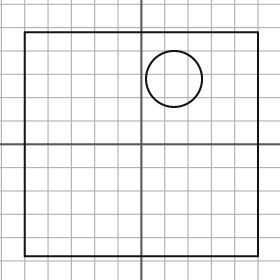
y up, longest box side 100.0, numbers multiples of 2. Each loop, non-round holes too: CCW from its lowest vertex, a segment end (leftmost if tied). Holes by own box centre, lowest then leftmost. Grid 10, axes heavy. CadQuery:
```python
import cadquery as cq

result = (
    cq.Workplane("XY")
    .moveTo(-50.0, -48.0)
    .lineTo(50.0, -48.0)
    .lineTo(50.0, 48.0)
    .lineTo(-50.0, 48.0)
    .close()
    .moveTo(14.0, 28.0)
    .circle(12.0)
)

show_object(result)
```